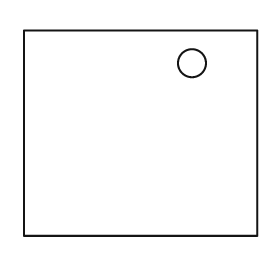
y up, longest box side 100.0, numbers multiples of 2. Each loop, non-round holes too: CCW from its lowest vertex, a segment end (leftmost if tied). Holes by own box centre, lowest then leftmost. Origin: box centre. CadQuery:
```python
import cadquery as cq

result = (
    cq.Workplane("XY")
    .moveTo(-50.0, -44.0)
    .lineTo(50.0, -44.0)
    .lineTo(50.0, 44.0)
    .lineTo(-50.0, 44.0)
    .close()
    .moveTo(22.0, 30.0)
    .circle(6.0)
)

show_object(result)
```